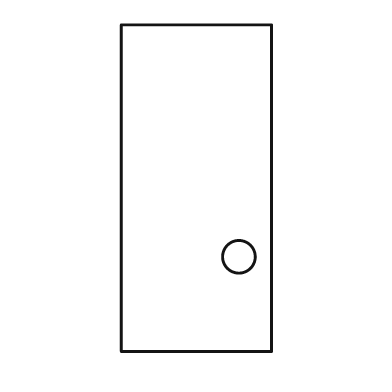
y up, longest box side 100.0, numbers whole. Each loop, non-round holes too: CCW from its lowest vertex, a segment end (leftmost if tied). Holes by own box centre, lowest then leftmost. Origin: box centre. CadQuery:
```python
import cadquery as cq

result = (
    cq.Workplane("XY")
    .moveTo(-23.0, -50.0)
    .lineTo(23.0, -50.0)
    .lineTo(23.0, 50.0)
    .lineTo(-23.0, 50.0)
    .close()
    .moveTo(13.0, -21.0)
    .circle(5.0)
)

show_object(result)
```